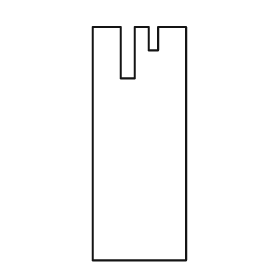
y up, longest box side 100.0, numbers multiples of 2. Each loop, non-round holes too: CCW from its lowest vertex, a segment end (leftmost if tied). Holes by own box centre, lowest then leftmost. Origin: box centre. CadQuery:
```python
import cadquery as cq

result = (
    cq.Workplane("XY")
    .moveTo(-20.0, -50.0)
    .lineTo(20.0, -50.0)
    .lineTo(20.0, 50.0)
    .lineTo(8.0, 50.0)
    .lineTo(8.0, 40.0)
    .lineTo(4.0, 40.0)
    .lineTo(4.0, 50.0)
    .lineTo(-2.0, 50.0)
    .lineTo(-2.0, 28.0)
    .lineTo(-8.0, 28.0)
    .lineTo(-8.0, 50.0)
    .lineTo(-20.0, 50.0)
    .close()
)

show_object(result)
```